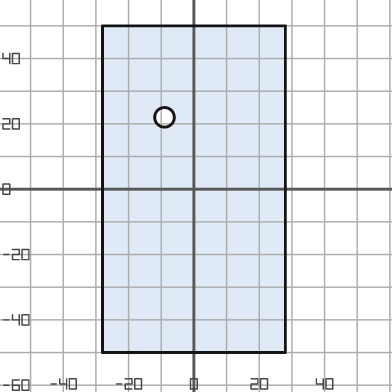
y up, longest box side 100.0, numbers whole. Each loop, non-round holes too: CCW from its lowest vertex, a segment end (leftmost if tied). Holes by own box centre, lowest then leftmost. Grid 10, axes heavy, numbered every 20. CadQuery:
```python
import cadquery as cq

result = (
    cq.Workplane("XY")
    .moveTo(-28.0, -50.0)
    .lineTo(28.0, -50.0)
    .lineTo(28.0, 50.0)
    .lineTo(-28.0, 50.0)
    .close()
    .moveTo(-9.0, 22.0)
    .circle(3.0)
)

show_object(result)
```